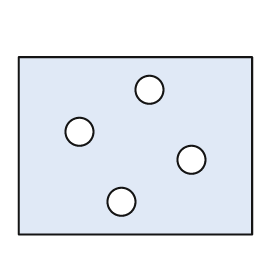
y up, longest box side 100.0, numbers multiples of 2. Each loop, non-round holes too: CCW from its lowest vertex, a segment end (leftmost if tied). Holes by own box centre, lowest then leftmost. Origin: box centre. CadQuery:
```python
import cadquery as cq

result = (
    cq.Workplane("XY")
    .moveTo(-50.0, -38.0)
    .lineTo(50.0, -38.0)
    .lineTo(50.0, 38.0)
    .lineTo(-50.0, 38.0)
    .close()
    .moveTo(-6.0, -24.0)
    .circle(6.0)
    .moveTo(24.0, -6.0)
    .circle(6.0)
    .moveTo(-24.0, 6.0)
    .circle(6.0)
    .moveTo(6.0, 24.0)
    .circle(6.0)
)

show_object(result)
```